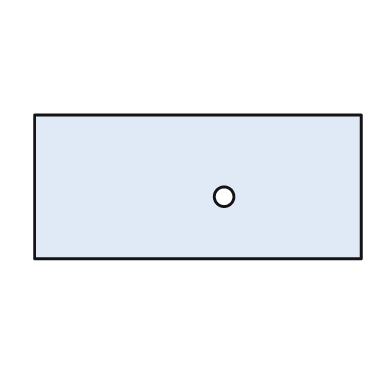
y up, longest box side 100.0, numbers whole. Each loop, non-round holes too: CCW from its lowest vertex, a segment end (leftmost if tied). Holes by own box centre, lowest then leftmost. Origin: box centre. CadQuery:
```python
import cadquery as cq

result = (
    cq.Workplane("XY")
    .moveTo(-50.0, -22.0)
    .lineTo(50.0, -22.0)
    .lineTo(50.0, 22.0)
    .lineTo(-50.0, 22.0)
    .close()
    .moveTo(8.0, -3.0)
    .circle(3.0)
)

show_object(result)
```